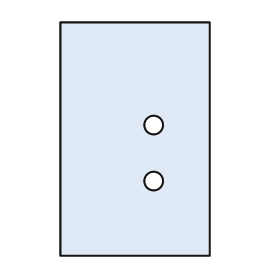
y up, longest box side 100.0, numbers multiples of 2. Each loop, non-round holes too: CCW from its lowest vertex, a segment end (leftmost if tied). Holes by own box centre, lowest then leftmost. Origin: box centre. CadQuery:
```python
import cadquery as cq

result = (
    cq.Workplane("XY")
    .moveTo(-32.0, -50.0)
    .lineTo(32.0, -50.0)
    .lineTo(32.0, 50.0)
    .lineTo(-32.0, 50.0)
    .close()
    .moveTo(8.0, -18.0)
    .circle(4.0)
    .moveTo(8.0, 6.0)
    .circle(4.0)
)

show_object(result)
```